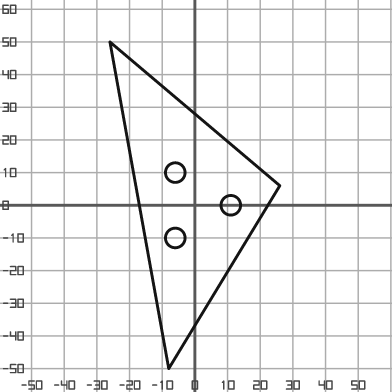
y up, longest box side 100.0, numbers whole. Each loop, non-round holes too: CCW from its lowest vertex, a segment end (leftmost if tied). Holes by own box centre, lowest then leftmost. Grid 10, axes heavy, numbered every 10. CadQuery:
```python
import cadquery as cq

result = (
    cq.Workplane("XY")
    .moveTo(-8.0, -50.0)
    .lineTo(26.0, 6.0)
    .lineTo(-26.0, 50.0)
    .close()
    .moveTo(-6.0, -10.0)
    .circle(3.0)
    .moveTo(11.0, 0.0)
    .circle(3.0)
    .moveTo(-6.0, 10.0)
    .circle(3.0)
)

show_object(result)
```